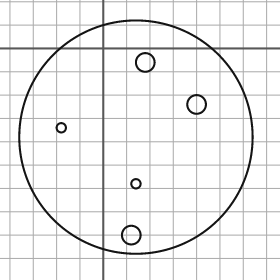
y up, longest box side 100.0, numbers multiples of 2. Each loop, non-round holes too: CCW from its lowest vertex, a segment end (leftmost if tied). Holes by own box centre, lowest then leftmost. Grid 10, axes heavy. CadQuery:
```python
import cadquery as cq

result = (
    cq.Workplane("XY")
    .moveTo(14.0, -38.0)
    .circle(50.0)
    .moveTo(12.0, -80.0)
    .circle(4.0)
    .moveTo(14.0, -58.0)
    .circle(2.0)
    .moveTo(-18.0, -34.0)
    .circle(2.0)
    .moveTo(40.0, -24.0)
    .circle(4.0)
    .moveTo(18.0, -6.0)
    .circle(4.0)
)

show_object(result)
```